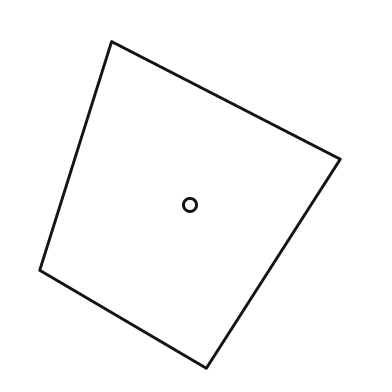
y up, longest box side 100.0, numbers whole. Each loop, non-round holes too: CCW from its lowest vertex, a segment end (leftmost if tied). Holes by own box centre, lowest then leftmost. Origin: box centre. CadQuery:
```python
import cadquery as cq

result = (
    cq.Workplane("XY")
    .moveTo(5.0, -50.0)
    .lineTo(46.0, 14.0)
    .lineTo(-24.0, 50.0)
    .lineTo(-46.0, -20.0)
    .close()
    .moveTo(0.0, 0.0)
    .circle(2.0)
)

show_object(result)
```